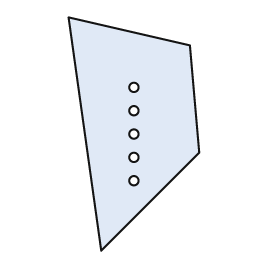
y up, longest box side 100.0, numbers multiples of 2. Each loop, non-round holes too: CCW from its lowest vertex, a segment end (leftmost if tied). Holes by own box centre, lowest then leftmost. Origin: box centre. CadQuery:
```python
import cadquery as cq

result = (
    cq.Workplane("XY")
    .moveTo(-14.0, -50.0)
    .lineTo(28.0, -8.0)
    .lineTo(24.0, 38.0)
    .lineTo(-28.0, 50.0)
    .close()
    .moveTo(0.0, -20.0)
    .circle(2.0)
    .moveTo(0.0, -10.0)
    .circle(2.0)
    .moveTo(0.0, 0.0)
    .circle(2.0)
    .moveTo(0.0, 10.0)
    .circle(2.0)
    .moveTo(0.0, 20.0)
    .circle(2.0)
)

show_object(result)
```